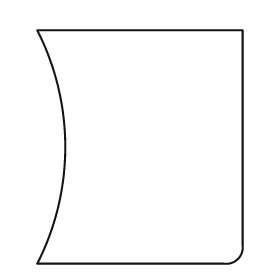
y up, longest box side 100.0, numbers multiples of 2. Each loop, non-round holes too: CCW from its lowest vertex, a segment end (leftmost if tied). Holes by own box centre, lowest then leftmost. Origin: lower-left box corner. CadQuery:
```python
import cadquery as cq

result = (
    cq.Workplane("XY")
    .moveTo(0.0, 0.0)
    .lineTo(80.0, 0.0)
    .threePointArc((86.0, 2.0), (88.0, 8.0))
    .lineTo(88.0, 100.0)
    .lineTo(0.0, 100.0)
    .threePointArc((12.0, 50.0), (0.0, 0.0))
    .close()
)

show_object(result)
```